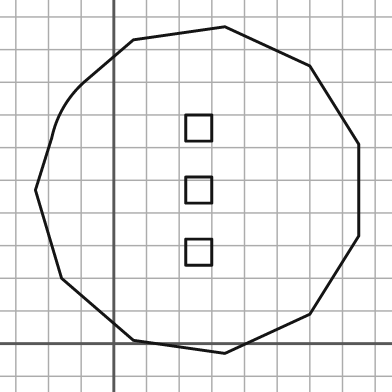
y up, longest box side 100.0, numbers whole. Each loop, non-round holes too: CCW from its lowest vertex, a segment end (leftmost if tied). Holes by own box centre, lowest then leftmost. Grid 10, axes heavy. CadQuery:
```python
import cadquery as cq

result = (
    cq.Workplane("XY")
    .moveTo(34.0, -3.0)
    .lineTo(60.0, 9.0)
    .lineTo(75.0, 33.0)
    .lineTo(75.0, 61.0)
    .lineTo(60.0, 85.0)
    .lineTo(34.0, 97.0)
    .lineTo(6.0, 93.0)
    .lineTo(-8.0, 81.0)
    .threePointArc((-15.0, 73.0), (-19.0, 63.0))
    .lineTo(-24.0, 47.0)
    .lineTo(-16.0, 20.0)
    .lineTo(6.0, 1.0)
    .close()
    .moveTo(22.0, 24.0)
    .lineTo(30.0, 24.0)
    .lineTo(30.0, 32.0)
    .lineTo(22.0, 32.0)
    .close()
    .moveTo(22.0, 43.0)
    .lineTo(30.0, 43.0)
    .lineTo(30.0, 51.0)
    .lineTo(22.0, 51.0)
    .close()
    .moveTo(22.0, 62.0)
    .lineTo(30.0, 62.0)
    .lineTo(30.0, 70.0)
    .lineTo(22.0, 70.0)
    .close()
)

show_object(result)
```